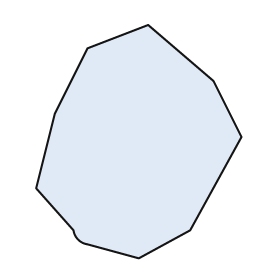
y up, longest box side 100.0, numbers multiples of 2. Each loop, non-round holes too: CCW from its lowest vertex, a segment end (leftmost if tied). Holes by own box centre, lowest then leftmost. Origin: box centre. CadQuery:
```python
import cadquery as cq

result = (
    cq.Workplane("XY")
    .moveTo(0.0, -50.0)
    .lineTo(22.0, -38.0)
    .lineTo(44.0, 2.0)
    .lineTo(32.0, 26.0)
    .lineTo(4.0, 50.0)
    .lineTo(-22.0, 40.0)
    .lineTo(-36.0, 12.0)
    .lineTo(-44.0, -20.0)
    .lineTo(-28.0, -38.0)
    .threePointArc((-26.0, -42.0), (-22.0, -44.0))
    .close()
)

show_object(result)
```